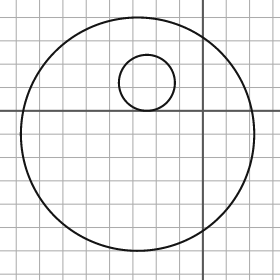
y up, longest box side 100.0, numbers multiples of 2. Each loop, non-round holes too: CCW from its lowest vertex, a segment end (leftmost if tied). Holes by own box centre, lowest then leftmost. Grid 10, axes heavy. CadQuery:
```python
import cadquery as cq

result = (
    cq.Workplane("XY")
    .moveTo(-28.0, -10.0)
    .circle(50.0)
    .moveTo(-24.0, 12.0)
    .circle(12.0)
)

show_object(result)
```